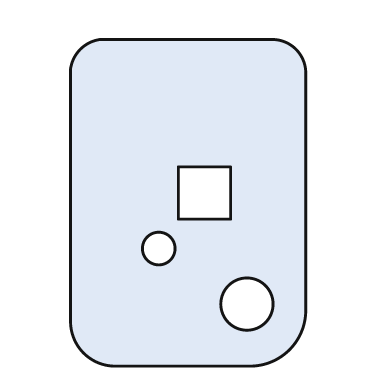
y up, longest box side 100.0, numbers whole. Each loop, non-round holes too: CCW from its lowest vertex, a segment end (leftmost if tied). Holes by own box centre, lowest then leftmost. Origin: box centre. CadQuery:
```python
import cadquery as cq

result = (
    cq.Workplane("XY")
    .moveTo(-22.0, -50.0)
    .lineTo(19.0, -50.0)
    .threePointArc((31.0, -45.0), (36.0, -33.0))
    .lineTo(36.0, 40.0)
    .threePointArc((33.0, 47.0), (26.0, 50.0))
    .lineTo(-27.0, 50.0)
    .threePointArc((-33.0, 47.0), (-36.0, 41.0))
    .lineTo(-36.0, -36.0)
    .threePointArc((-32.0, -46.0), (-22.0, -50.0))
    .close()
    .moveTo(18.0, -31.0)
    .circle(8.0)
    .moveTo(-9.0, -14.0)
    .circle(5.0)
    .moveTo(-3.0, -5.0)
    .lineTo(13.0, -5.0)
    .lineTo(13.0, 11.0)
    .lineTo(-3.0, 11.0)
    .close()
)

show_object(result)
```